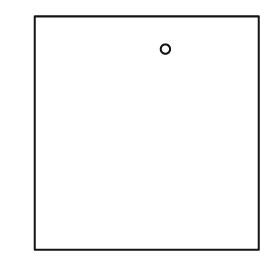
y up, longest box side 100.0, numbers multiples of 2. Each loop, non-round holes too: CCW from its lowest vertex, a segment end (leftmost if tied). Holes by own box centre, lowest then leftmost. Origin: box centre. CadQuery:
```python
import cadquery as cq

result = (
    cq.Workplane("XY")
    .moveTo(-48.0, -50.0)
    .lineTo(48.0, -50.0)
    .lineTo(48.0, 50.0)
    .lineTo(-48.0, 50.0)
    .close()
    .moveTo(8.0, 36.0)
    .circle(2.0)
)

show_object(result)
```